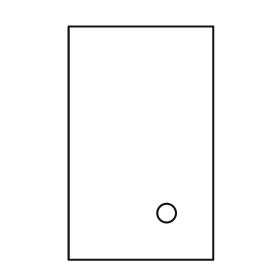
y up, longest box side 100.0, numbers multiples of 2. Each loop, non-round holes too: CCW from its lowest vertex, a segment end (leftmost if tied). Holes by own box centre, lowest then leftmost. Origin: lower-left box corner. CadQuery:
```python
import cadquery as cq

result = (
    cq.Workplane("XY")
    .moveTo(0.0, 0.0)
    .lineTo(62.0, 0.0)
    .lineTo(62.0, 100.0)
    .lineTo(0.0, 100.0)
    .close()
    .moveTo(42.0, 20.0)
    .circle(4.0)
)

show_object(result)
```